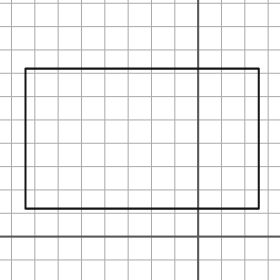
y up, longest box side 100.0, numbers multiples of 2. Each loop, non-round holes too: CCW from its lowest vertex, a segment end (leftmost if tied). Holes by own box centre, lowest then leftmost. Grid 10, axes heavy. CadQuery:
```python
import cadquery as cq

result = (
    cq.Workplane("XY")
    .moveTo(-74.0, 12.0)
    .lineTo(26.0, 12.0)
    .lineTo(26.0, 72.0)
    .lineTo(-74.0, 72.0)
    .close()
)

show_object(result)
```